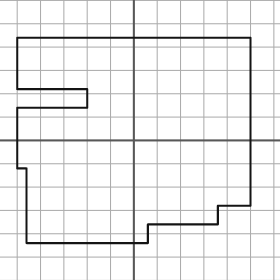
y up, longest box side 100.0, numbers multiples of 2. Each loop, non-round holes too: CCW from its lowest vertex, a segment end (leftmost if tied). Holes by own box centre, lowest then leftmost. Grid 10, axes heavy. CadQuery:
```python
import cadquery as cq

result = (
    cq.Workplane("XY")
    .moveTo(-46.0, -44.0)
    .lineTo(6.0, -44.0)
    .lineTo(6.0, -36.0)
    .lineTo(36.0, -36.0)
    .lineTo(36.0, -28.0)
    .lineTo(50.0, -28.0)
    .lineTo(50.0, 44.0)
    .lineTo(-50.0, 44.0)
    .lineTo(-50.0, 22.0)
    .lineTo(-20.0, 22.0)
    .lineTo(-20.0, 14.0)
    .lineTo(-50.0, 14.0)
    .lineTo(-50.0, -12.0)
    .lineTo(-46.0, -12.0)
    .close()
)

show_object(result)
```